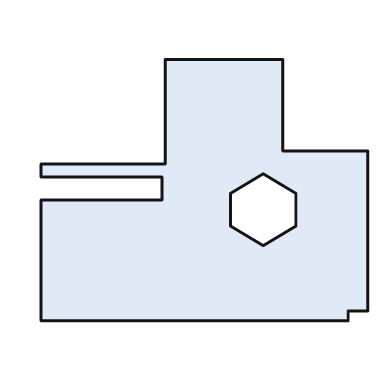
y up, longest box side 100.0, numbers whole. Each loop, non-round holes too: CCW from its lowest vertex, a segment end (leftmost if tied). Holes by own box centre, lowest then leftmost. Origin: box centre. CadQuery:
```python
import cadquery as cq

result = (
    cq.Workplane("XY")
    .moveTo(-50.0, -40.0)
    .lineTo(44.0, -40.0)
    .lineTo(44.0, -37.0)
    .lineTo(50.0, -37.0)
    .lineTo(50.0, 12.0)
    .lineTo(24.0, 12.0)
    .lineTo(24.0, 40.0)
    .lineTo(-12.0, 40.0)
    .lineTo(-12.0, 8.0)
    .lineTo(-50.0, 8.0)
    .lineTo(-50.0, 4.0)
    .lineTo(-13.0, 4.0)
    .lineTo(-13.0, -3.0)
    .lineTo(-50.0, -3.0)
    .close()
    .moveTo(18.0, -17.0)
    .lineTo(28.0, -11.0)
    .lineTo(28.0, -1.0)
    .lineTo(18.0, 5.0)
    .lineTo(8.0, -1.0)
    .lineTo(8.0, -11.0)
    .close()
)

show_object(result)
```